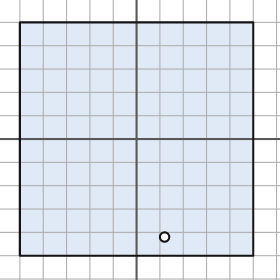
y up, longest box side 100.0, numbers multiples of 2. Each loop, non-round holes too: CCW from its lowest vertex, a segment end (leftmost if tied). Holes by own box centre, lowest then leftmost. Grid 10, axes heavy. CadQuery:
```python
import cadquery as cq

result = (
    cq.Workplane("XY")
    .moveTo(-50.0, -50.0)
    .lineTo(50.0, -50.0)
    .lineTo(50.0, 50.0)
    .lineTo(-50.0, 50.0)
    .close()
    .moveTo(12.0, -42.0)
    .circle(2.0)
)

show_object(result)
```